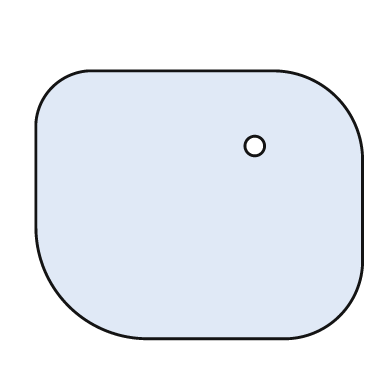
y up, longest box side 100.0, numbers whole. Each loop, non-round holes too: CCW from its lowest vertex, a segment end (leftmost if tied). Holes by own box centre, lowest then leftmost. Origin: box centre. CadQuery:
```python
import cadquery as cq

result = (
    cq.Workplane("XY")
    .moveTo(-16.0, -41.0)
    .lineTo(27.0, -41.0)
    .threePointArc((43.0, -34.0), (50.0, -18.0))
    .lineTo(50.0, 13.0)
    .threePointArc((42.0, 33.0), (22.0, 41.0))
    .lineTo(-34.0, 41.0)
    .threePointArc((-45.0, 36.0), (-50.0, 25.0))
    .lineTo(-50.0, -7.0)
    .threePointArc((-40.0, -31.0), (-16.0, -41.0))
    .close()
    .moveTo(17.0, 18.0)
    .circle(3.0)
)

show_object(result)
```